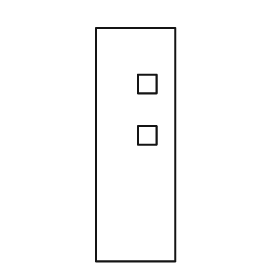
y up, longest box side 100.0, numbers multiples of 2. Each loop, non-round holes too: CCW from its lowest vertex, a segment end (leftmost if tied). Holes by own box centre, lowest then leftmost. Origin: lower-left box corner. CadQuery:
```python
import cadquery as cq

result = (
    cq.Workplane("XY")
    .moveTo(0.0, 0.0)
    .lineTo(34.0, 0.0)
    .lineTo(34.0, 100.0)
    .lineTo(0.0, 100.0)
    .close()
    .moveTo(18.0, 50.0)
    .lineTo(26.0, 50.0)
    .lineTo(26.0, 58.0)
    .lineTo(18.0, 58.0)
    .close()
    .moveTo(18.0, 72.0)
    .lineTo(26.0, 72.0)
    .lineTo(26.0, 80.0)
    .lineTo(18.0, 80.0)
    .close()
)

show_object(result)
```